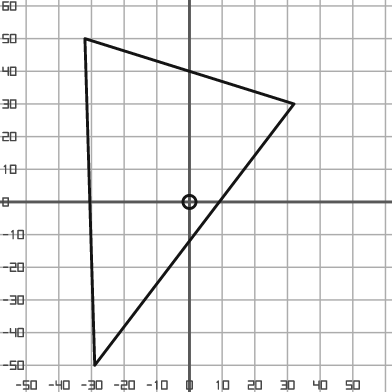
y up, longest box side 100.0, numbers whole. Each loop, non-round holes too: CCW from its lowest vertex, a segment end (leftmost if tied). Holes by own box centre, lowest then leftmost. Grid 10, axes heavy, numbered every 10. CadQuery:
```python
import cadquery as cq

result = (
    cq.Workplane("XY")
    .moveTo(-29.0, -50.0)
    .lineTo(32.0, 30.0)
    .lineTo(-32.0, 50.0)
    .close()
    .moveTo(0.0, 0.0)
    .circle(2.0)
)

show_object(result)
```